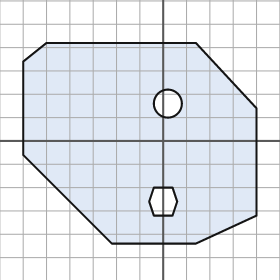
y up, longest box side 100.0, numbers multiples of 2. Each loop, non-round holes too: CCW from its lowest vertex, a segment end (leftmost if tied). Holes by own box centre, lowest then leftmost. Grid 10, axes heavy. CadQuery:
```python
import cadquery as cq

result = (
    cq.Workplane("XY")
    .moveTo(-22.0, -44.0)
    .lineTo(14.0, -44.0)
    .lineTo(40.0, -32.0)
    .lineTo(40.0, 14.0)
    .lineTo(14.0, 42.0)
    .lineTo(-50.0, 42.0)
    .lineTo(-60.0, 34.0)
    .lineTo(-60.0, -6.0)
    .close()
    .moveTo(-4.0, -32.0)
    .lineTo(4.0, -32.0)
    .lineTo(6.0, -26.0)
    .lineTo(4.0, -20.0)
    .lineTo(-4.0, -20.0)
    .lineTo(-6.0, -26.0)
    .close()
    .moveTo(2.0, 16.0)
    .circle(6.0)
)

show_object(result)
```